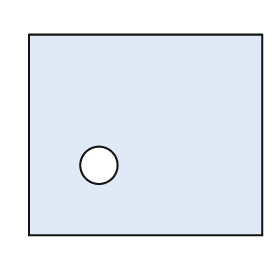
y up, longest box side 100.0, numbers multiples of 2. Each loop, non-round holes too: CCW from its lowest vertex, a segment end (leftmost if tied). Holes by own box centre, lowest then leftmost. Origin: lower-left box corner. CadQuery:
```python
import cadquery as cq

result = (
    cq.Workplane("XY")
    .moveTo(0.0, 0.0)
    .lineTo(100.0, 0.0)
    .lineTo(100.0, 86.0)
    .lineTo(0.0, 86.0)
    .close()
    .moveTo(30.0, 30.0)
    .circle(8.0)
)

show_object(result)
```